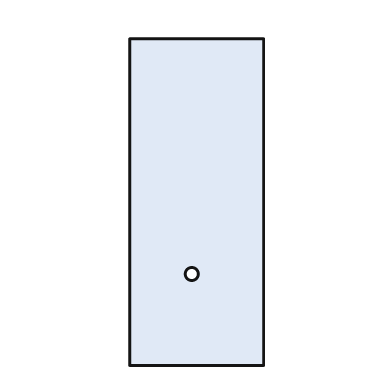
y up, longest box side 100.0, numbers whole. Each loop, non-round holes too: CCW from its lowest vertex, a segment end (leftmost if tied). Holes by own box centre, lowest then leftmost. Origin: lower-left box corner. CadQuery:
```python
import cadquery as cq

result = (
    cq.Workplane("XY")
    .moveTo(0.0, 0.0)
    .lineTo(41.0, 0.0)
    .lineTo(41.0, 100.0)
    .lineTo(0.0, 100.0)
    .close()
    .moveTo(19.0, 28.0)
    .circle(2.0)
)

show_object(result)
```